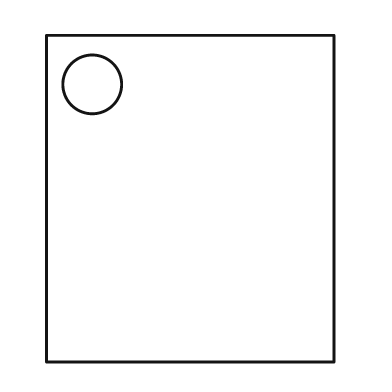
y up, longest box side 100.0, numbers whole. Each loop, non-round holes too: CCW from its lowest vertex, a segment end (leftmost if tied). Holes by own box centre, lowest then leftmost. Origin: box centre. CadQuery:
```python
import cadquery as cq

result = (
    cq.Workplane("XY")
    .moveTo(-44.0, -50.0)
    .lineTo(44.0, -50.0)
    .lineTo(44.0, 50.0)
    .lineTo(-44.0, 50.0)
    .close()
    .moveTo(-30.0, 35.0)
    .circle(9.0)
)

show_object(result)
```